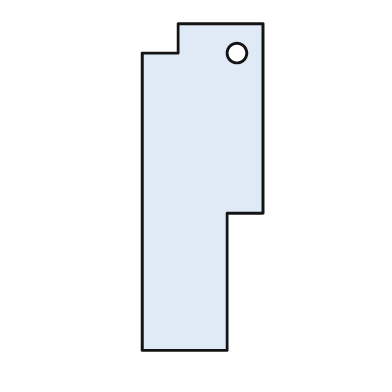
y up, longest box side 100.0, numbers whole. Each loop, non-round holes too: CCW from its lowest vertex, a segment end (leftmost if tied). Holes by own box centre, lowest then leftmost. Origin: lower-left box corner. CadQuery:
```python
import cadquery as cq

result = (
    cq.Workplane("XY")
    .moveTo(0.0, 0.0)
    .lineTo(26.0, 0.0)
    .lineTo(26.0, 42.0)
    .lineTo(37.0, 42.0)
    .lineTo(37.0, 100.0)
    .lineTo(11.0, 100.0)
    .lineTo(11.0, 91.0)
    .lineTo(0.0, 91.0)
    .close()
    .moveTo(29.0, 91.0)
    .circle(3.0)
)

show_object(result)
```